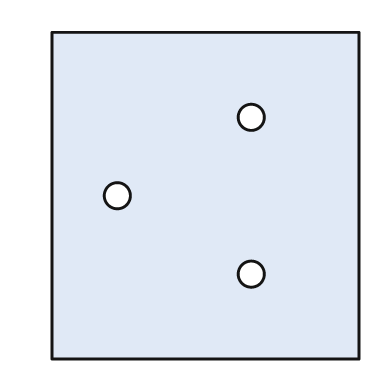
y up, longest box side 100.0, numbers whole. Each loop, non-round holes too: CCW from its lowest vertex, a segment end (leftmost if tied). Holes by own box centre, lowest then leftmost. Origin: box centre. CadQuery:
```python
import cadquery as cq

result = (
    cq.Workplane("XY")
    .moveTo(-47.0, -50.0)
    .lineTo(47.0, -50.0)
    .lineTo(47.0, 50.0)
    .lineTo(-47.0, 50.0)
    .close()
    .moveTo(14.0, -24.0)
    .circle(4.0)
    .moveTo(-27.0, 0.0)
    .circle(4.0)
    .moveTo(14.0, 24.0)
    .circle(4.0)
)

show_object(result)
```